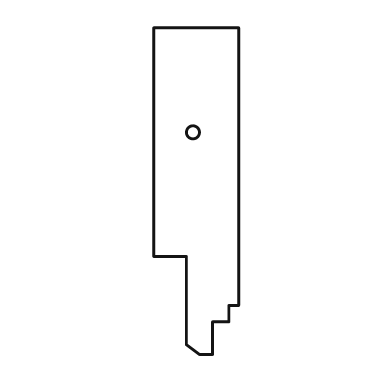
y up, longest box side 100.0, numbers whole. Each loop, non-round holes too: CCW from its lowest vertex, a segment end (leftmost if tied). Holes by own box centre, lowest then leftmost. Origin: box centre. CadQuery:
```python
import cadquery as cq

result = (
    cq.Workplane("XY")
    .moveTo(1.0, -50.0)
    .lineTo(5.0, -50.0)
    .lineTo(5.0, -40.0)
    .lineTo(10.0, -40.0)
    .lineTo(10.0, -35.0)
    .lineTo(13.0, -35.0)
    .lineTo(13.0, 50.0)
    .lineTo(-13.0, 50.0)
    .lineTo(-13.0, -20.0)
    .lineTo(-3.0, -20.0)
    .lineTo(-3.0, -47.0)
    .close()
    .moveTo(-1.0, 18.0)
    .circle(2.0)
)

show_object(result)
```